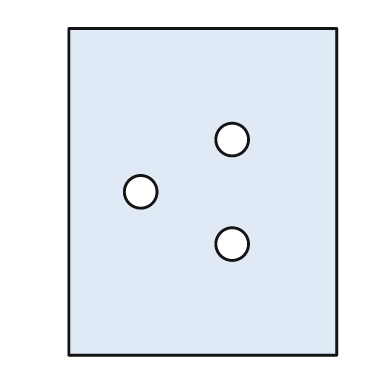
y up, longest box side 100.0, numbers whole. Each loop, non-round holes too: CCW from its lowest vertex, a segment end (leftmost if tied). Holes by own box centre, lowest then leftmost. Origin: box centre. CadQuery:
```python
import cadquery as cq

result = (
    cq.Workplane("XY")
    .moveTo(-41.0, -50.0)
    .lineTo(41.0, -50.0)
    .lineTo(41.0, 50.0)
    .lineTo(-41.0, 50.0)
    .close()
    .moveTo(9.0, -16.0)
    .circle(5.0)
    .moveTo(-19.0, 0.0)
    .circle(5.0)
    .moveTo(9.0, 16.0)
    .circle(5.0)
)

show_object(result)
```